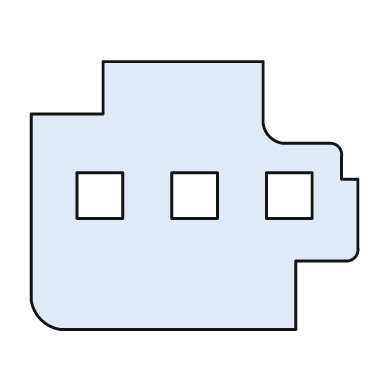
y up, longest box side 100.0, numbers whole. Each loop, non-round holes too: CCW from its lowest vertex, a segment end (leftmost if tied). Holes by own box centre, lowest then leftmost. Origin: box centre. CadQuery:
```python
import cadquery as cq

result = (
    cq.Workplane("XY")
    .moveTo(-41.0, -41.0)
    .lineTo(31.0, -41.0)
    .lineTo(31.0, -20.0)
    .lineTo(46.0, -20.0)
    .threePointArc((49.0, -19.0), (50.0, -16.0))
    .lineTo(50.0, 5.0)
    .lineTo(45.0, 5.0)
    .lineTo(45.0, 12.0)
    .threePointArc((44.0, 15.0), (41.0, 16.0))
    .lineTo(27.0, 16.0)
    .threePointArc((23.0, 18.0), (21.0, 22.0))
    .lineTo(21.0, 41.0)
    .lineTo(-28.0, 41.0)
    .lineTo(-28.0, 25.0)
    .lineTo(-50.0, 25.0)
    .lineTo(-50.0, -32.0)
    .threePointArc((-47.0, -38.0), (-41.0, -41.0))
    .close()
    .moveTo(-36.0, -7.0)
    .lineTo(-22.0, -7.0)
    .lineTo(-22.0, 7.0)
    .lineTo(-36.0, 7.0)
    .close()
    .moveTo(-7.0, -7.0)
    .lineTo(7.0, -7.0)
    .lineTo(7.0, 7.0)
    .lineTo(-7.0, 7.0)
    .close()
    .moveTo(22.0, -7.0)
    .lineTo(36.0, -7.0)
    .lineTo(36.0, 7.0)
    .lineTo(22.0, 7.0)
    .close()
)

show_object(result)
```